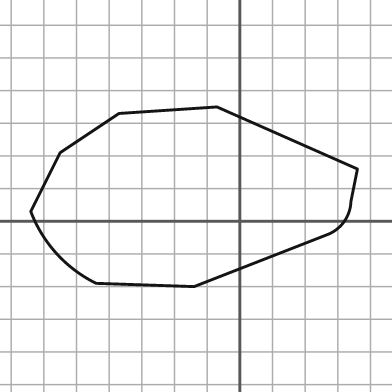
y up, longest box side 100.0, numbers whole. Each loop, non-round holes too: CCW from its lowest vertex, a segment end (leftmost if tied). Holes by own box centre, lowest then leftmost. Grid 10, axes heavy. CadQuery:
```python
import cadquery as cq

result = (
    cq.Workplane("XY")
    .moveTo(-14.0, -20.0)
    .lineTo(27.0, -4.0)
    .threePointArc((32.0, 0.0), (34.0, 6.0))
    .lineTo(36.0, 16.0)
    .lineTo(-7.0, 35.0)
    .lineTo(-37.0, 33.0)
    .lineTo(-55.0, 21.0)
    .lineTo(-64.0, 3.0)
    .threePointArc((-56.0, -10.0), (-44.0, -19.0))
    .close()
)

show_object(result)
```